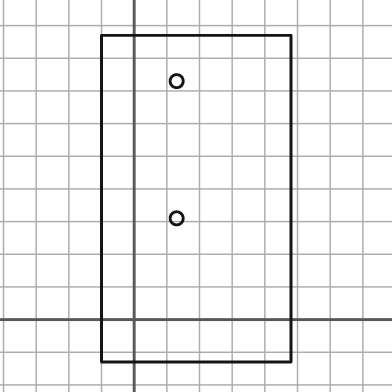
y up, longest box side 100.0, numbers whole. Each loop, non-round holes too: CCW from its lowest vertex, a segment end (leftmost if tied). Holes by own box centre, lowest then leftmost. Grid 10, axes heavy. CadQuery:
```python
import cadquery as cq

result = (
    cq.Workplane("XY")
    .moveTo(-10.0, -13.0)
    .lineTo(48.0, -13.0)
    .lineTo(48.0, 87.0)
    .lineTo(-10.0, 87.0)
    .close()
    .moveTo(13.0, 31.0)
    .circle(2.0)
    .moveTo(13.0, 73.0)
    .circle(2.0)
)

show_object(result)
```